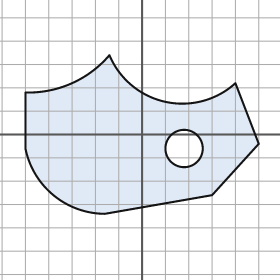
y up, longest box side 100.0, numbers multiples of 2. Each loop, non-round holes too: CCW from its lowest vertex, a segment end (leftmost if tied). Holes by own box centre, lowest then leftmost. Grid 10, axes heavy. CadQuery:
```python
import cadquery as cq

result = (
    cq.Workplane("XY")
    .moveTo(-16.0, -34.0)
    .lineTo(30.0, -26.0)
    .lineTo(50.0, -4.0)
    .lineTo(40.0, 22.0)
    .threePointArc((10.0, 14.0), (-14.0, 34.0))
    .threePointArc((-30.0, 22.0), (-50.0, 18.0))
    .lineTo(-50.0, -6.0)
    .threePointArc((-38.0, -26.0), (-16.0, -34.0))
    .close()
    .moveTo(18.0, -6.0)
    .circle(8.0)
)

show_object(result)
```